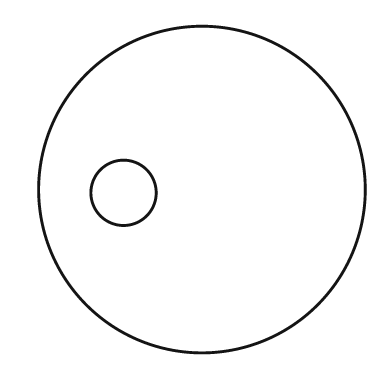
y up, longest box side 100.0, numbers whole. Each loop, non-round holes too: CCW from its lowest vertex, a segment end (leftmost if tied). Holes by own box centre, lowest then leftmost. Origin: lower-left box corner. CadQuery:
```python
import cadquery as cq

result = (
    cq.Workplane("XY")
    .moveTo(50.0, 50.0)
    .circle(50.0)
    .moveTo(26.0, 49.0)
    .circle(10.0)
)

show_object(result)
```